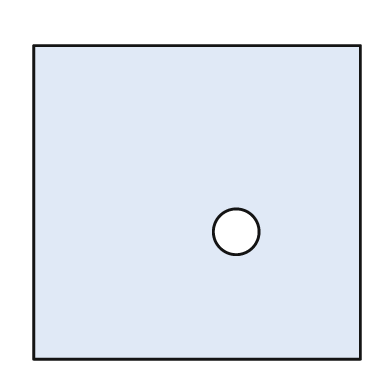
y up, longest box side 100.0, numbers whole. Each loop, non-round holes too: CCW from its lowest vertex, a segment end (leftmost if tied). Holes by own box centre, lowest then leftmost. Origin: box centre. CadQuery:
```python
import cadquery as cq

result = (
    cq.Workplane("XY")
    .moveTo(-50.0, -48.0)
    .lineTo(50.0, -48.0)
    .lineTo(50.0, 48.0)
    .lineTo(-50.0, 48.0)
    .close()
    .moveTo(12.0, -9.0)
    .circle(7.0)
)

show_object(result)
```